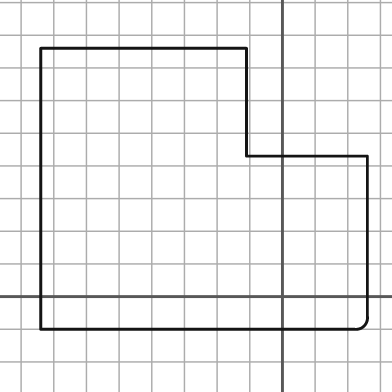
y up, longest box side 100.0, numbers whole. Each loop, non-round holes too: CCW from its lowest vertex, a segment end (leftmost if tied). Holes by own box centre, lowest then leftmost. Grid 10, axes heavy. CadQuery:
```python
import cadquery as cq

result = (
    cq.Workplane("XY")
    .moveTo(-74.0, -10.0)
    .lineTo(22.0, -10.0)
    .threePointArc((25.0, -9.0), (26.0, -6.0))
    .lineTo(26.0, 43.0)
    .lineTo(-11.0, 43.0)
    .lineTo(-11.0, 76.0)
    .lineTo(-74.0, 76.0)
    .close()
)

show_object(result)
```